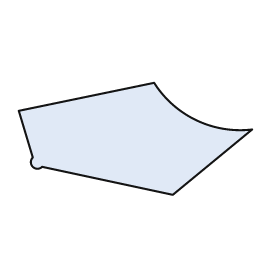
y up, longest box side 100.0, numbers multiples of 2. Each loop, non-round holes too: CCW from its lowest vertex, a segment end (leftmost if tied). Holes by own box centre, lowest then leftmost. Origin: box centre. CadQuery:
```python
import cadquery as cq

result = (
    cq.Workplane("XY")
    .moveTo(16.0, -24.0)
    .lineTo(50.0, 4.0)
    .threePointArc((26.0, 8.0), (8.0, 24.0))
    .lineTo(-50.0, 12.0)
    .lineTo(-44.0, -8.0)
    .threePointArc((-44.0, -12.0), (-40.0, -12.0))
    .close()
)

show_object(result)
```